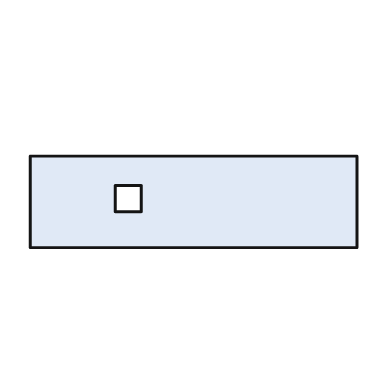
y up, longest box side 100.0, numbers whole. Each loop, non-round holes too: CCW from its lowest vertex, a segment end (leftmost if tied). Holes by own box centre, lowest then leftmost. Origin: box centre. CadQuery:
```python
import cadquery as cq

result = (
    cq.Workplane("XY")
    .moveTo(-50.0, -14.0)
    .lineTo(50.0, -14.0)
    .lineTo(50.0, 14.0)
    .lineTo(-50.0, 14.0)
    .close()
    .moveTo(-24.0, -3.0)
    .lineTo(-16.0, -3.0)
    .lineTo(-16.0, 5.0)
    .lineTo(-24.0, 5.0)
    .close()
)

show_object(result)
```